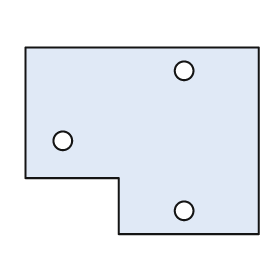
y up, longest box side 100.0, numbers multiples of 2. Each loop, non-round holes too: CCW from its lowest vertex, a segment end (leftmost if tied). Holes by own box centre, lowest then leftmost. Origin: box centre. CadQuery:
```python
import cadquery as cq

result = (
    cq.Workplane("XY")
    .moveTo(-10.0, -40.0)
    .lineTo(50.0, -40.0)
    .lineTo(50.0, 40.0)
    .lineTo(-50.0, 40.0)
    .lineTo(-50.0, -16.0)
    .lineTo(-10.0, -16.0)
    .close()
    .moveTo(18.0, -30.0)
    .circle(4.0)
    .moveTo(-34.0, 0.0)
    .circle(4.0)
    .moveTo(18.0, 30.0)
    .circle(4.0)
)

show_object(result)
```